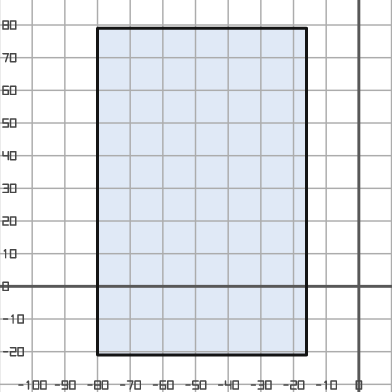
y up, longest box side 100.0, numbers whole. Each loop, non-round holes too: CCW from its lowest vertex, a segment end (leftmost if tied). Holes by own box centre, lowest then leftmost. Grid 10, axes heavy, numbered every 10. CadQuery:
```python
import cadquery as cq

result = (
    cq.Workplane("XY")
    .moveTo(-80.0, -21.0)
    .lineTo(-16.0, -21.0)
    .lineTo(-16.0, 79.0)
    .lineTo(-80.0, 79.0)
    .close()
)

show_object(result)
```